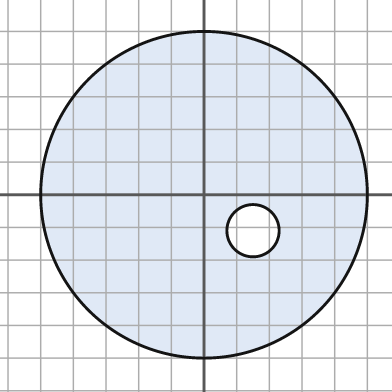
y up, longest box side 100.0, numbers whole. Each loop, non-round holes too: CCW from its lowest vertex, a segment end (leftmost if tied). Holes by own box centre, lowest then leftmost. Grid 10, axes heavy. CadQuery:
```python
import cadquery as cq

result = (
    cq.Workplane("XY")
    .moveTo(0.0, 0.0)
    .circle(50.0)
    .moveTo(15.0, -11.0)
    .circle(8.0)
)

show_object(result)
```